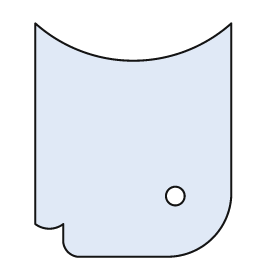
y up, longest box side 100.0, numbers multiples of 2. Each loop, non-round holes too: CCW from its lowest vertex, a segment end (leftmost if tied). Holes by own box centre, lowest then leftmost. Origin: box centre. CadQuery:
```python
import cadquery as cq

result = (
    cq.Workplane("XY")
    .moveTo(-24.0, -50.0)
    .lineTo(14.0, -50.0)
    .threePointArc((34.0, -42.0), (42.0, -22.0))
    .lineTo(42.0, 50.0)
    .threePointArc((0.0, 34.0), (-42.0, 50.0))
    .lineTo(-42.0, -36.0)
    .threePointArc((-36.0, -38.0), (-30.0, -36.0))
    .lineTo(-30.0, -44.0)
    .threePointArc((-28.0, -48.0), (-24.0, -50.0))
    .close()
    .moveTo(18.0, -24.0)
    .circle(4.0)
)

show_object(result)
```